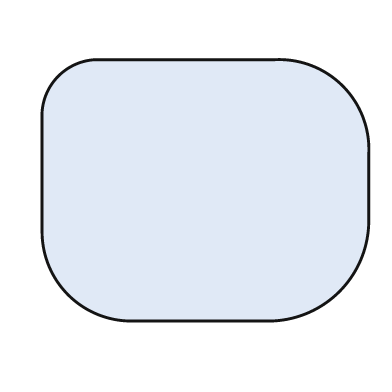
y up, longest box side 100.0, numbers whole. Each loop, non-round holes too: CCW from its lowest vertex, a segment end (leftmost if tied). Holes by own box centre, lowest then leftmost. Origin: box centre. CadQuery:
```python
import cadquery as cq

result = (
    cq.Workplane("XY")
    .moveTo(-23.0, -40.0)
    .lineTo(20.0, -40.0)
    .threePointArc((41.0, -31.0), (50.0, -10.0))
    .lineTo(50.0, 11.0)
    .threePointArc((42.0, 32.0), (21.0, 40.0))
    .lineTo(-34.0, 40.0)
    .threePointArc((-45.0, 35.0), (-50.0, 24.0))
    .lineTo(-50.0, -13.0)
    .threePointArc((-42.0, -32.0), (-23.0, -40.0))
    .close()
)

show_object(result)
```